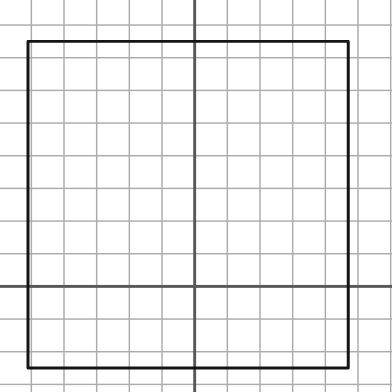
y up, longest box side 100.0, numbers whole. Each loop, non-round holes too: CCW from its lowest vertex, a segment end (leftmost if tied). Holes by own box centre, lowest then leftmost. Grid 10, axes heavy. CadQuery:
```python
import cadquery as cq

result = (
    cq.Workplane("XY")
    .moveTo(-51.0, -25.0)
    .lineTo(47.0, -25.0)
    .lineTo(47.0, 75.0)
    .lineTo(-51.0, 75.0)
    .close()
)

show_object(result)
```